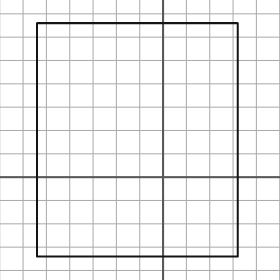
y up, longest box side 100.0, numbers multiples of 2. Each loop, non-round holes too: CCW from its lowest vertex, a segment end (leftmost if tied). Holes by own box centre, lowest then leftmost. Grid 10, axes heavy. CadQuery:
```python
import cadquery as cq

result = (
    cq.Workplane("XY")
    .moveTo(-54.0, -34.0)
    .lineTo(32.0, -34.0)
    .lineTo(32.0, 66.0)
    .lineTo(-54.0, 66.0)
    .close()
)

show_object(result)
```